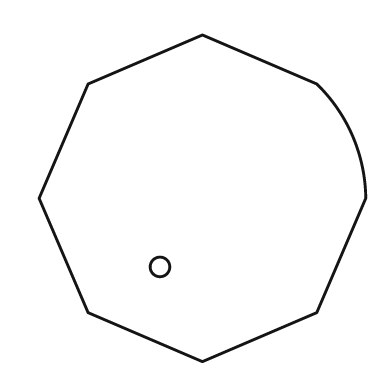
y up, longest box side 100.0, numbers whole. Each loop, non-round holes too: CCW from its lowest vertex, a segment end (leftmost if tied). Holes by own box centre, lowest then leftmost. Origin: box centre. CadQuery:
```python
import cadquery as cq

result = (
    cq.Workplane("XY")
    .moveTo(0.0, -50.0)
    .lineTo(35.0, -35.0)
    .lineTo(50.0, 0.0)
    .threePointArc((46.0, 19.0), (35.0, 35.0))
    .lineTo(0.0, 50.0)
    .lineTo(-35.0, 35.0)
    .lineTo(-50.0, 0.0)
    .lineTo(-35.0, -35.0)
    .close()
    .moveTo(-13.0, -21.0)
    .circle(3.0)
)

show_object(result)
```